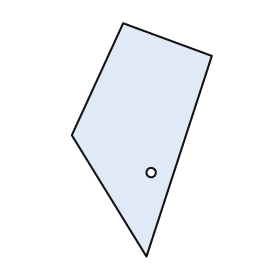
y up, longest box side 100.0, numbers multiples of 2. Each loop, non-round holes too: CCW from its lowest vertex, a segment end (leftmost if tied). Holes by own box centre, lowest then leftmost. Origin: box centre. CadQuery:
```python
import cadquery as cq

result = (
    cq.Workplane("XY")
    .moveTo(2.0, -50.0)
    .lineTo(30.0, 36.0)
    .lineTo(-8.0, 50.0)
    .lineTo(-30.0, 2.0)
    .close()
    .moveTo(4.0, -14.0)
    .circle(2.0)
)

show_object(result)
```